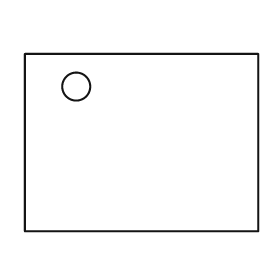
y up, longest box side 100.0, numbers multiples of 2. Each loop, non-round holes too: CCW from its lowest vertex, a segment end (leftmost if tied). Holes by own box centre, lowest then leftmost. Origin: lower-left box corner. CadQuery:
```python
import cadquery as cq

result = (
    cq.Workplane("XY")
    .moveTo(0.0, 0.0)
    .lineTo(100.0, 0.0)
    .lineTo(100.0, 76.0)
    .lineTo(0.0, 76.0)
    .close()
    .moveTo(22.0, 62.0)
    .circle(6.0)
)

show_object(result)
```